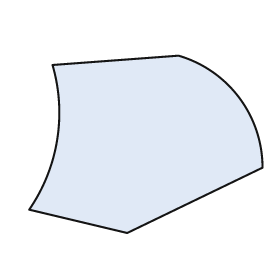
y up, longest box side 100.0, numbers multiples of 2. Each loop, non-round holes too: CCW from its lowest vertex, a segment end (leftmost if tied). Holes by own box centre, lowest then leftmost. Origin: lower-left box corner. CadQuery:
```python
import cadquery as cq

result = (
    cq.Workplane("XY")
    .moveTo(42.0, 0.0)
    .lineTo(100.0, 28.0)
    .threePointArc((90.0, 58.0), (64.0, 76.0))
    .lineTo(10.0, 72.0)
    .threePointArc((12.0, 40.0), (0.0, 10.0))
    .close()
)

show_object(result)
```